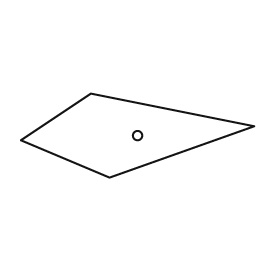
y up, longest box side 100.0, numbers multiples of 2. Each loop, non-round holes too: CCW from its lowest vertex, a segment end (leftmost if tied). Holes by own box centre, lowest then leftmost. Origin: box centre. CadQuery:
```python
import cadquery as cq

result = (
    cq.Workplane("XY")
    .moveTo(-12.0, -18.0)
    .lineTo(50.0, 4.0)
    .lineTo(-20.0, 18.0)
    .lineTo(-50.0, -2.0)
    .close()
    .moveTo(0.0, 0.0)
    .circle(2.0)
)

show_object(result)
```